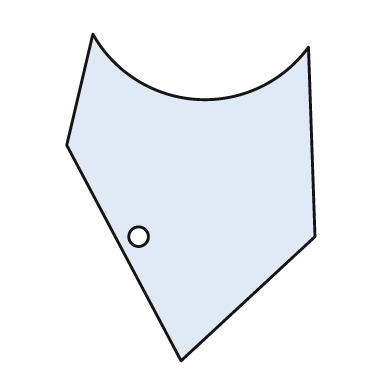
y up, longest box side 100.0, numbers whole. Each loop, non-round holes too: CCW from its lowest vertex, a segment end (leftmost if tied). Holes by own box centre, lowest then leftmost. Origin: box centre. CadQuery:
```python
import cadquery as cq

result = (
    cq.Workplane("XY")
    .moveTo(-3.0, -50.0)
    .lineTo(38.0, -12.0)
    .lineTo(36.0, 46.0)
    .threePointArc((2.0, 30.0), (-30.0, 50.0))
    .lineTo(-38.0, 16.0)
    .close()
    .moveTo(-16.0, -12.0)
    .circle(3.0)
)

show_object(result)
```